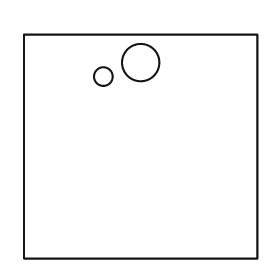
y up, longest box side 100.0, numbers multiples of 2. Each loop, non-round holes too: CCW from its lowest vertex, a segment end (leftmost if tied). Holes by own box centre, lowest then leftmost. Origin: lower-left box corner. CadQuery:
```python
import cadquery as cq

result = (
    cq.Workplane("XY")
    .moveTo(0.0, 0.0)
    .lineTo(100.0, 0.0)
    .lineTo(100.0, 96.0)
    .lineTo(0.0, 96.0)
    .close()
    .moveTo(34.0, 78.0)
    .circle(4.0)
    .moveTo(50.0, 84.0)
    .circle(8.0)
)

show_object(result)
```